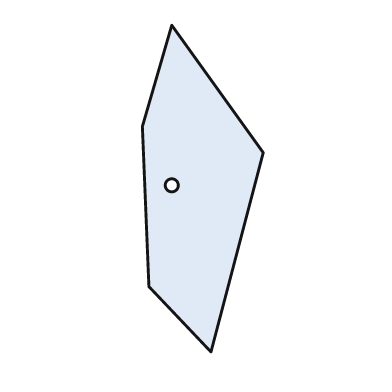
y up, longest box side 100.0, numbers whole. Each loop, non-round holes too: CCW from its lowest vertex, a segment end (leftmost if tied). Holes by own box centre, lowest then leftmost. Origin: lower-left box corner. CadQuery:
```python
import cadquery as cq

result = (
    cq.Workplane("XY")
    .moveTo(21.0, 0.0)
    .lineTo(37.0, 61.0)
    .lineTo(9.0, 100.0)
    .lineTo(0.0, 69.0)
    .lineTo(2.0, 20.0)
    .close()
    .moveTo(9.0, 51.0)
    .circle(2.0)
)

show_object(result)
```